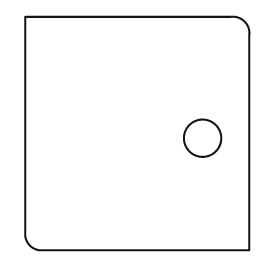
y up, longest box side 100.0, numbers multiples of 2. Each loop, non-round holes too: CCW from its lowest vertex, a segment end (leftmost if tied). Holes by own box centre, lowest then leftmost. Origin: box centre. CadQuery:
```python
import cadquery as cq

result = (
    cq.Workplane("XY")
    .moveTo(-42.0, -50.0)
    .lineTo(48.0, -50.0)
    .lineTo(48.0, 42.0)
    .threePointArc((46.0, 48.0), (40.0, 50.0))
    .lineTo(-48.0, 50.0)
    .lineTo(-48.0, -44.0)
    .threePointArc((-46.0, -48.0), (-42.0, -50.0))
    .close()
    .moveTo(28.0, -2.0)
    .circle(8.0)
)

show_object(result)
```